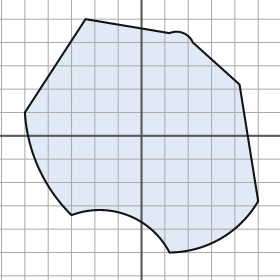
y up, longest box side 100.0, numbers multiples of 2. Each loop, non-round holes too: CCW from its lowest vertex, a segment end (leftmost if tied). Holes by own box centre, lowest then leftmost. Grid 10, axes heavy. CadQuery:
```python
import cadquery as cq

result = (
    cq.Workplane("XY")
    .moveTo(12.0, -50.0)
    .threePointArc((34.0, -44.0), (50.0, -28.0))
    .lineTo(42.0, 22.0)
    .lineTo(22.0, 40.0)
    .threePointArc((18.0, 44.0), (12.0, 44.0))
    .lineTo(-24.0, 50.0)
    .lineTo(-50.0, 10.0)
    .threePointArc((-44.0, -14.0), (-30.0, -34.0))
    .threePointArc((-6.0, -34.0), (12.0, -50.0))
    .close()
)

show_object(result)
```